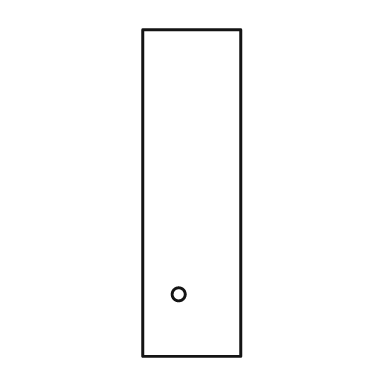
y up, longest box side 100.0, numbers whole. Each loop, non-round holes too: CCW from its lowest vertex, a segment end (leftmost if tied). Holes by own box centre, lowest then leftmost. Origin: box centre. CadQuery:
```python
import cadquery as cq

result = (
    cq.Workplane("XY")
    .moveTo(-15.0, -50.0)
    .lineTo(15.0, -50.0)
    .lineTo(15.0, 50.0)
    .lineTo(-15.0, 50.0)
    .close()
    .moveTo(-4.0, -31.0)
    .circle(2.0)
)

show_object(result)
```